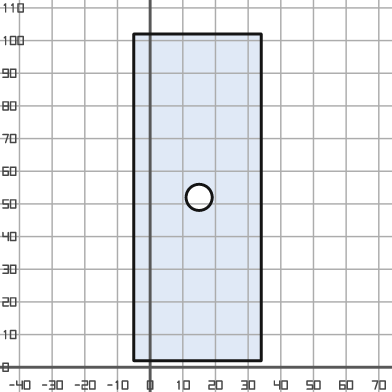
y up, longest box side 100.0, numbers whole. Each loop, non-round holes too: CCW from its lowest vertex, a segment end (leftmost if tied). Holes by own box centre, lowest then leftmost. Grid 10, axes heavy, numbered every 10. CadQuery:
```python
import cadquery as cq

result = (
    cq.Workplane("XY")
    .moveTo(-5.0, 2.0)
    .lineTo(34.0, 2.0)
    .lineTo(34.0, 102.0)
    .lineTo(-5.0, 102.0)
    .close()
    .moveTo(15.0, 52.0)
    .circle(4.0)
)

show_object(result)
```